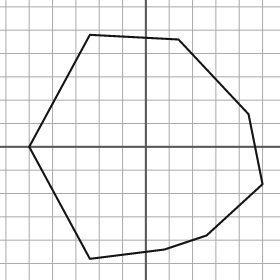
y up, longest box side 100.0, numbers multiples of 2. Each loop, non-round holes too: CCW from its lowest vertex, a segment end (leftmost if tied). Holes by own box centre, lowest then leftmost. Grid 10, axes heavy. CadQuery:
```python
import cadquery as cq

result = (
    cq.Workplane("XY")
    .moveTo(-24.0, -48.0)
    .lineTo(8.0, -44.0)
    .lineTo(26.0, -38.0)
    .lineTo(50.0, -16.0)
    .lineTo(44.0, 14.0)
    .lineTo(14.0, 46.0)
    .lineTo(-24.0, 48.0)
    .lineTo(-50.0, 0.0)
    .close()
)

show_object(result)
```